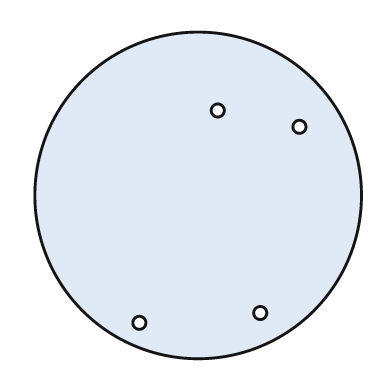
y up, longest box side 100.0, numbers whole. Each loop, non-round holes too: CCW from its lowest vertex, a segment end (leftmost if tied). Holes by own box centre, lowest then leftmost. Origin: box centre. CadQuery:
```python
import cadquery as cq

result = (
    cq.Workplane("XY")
    .moveTo(0.0, 0.0)
    .circle(50.0)
    .moveTo(-18.0, -39.0)
    .circle(2.0)
    .moveTo(19.0, -36.0)
    .circle(2.0)
    .moveTo(31.0, 21.0)
    .circle(2.0)
    .moveTo(6.0, 26.0)
    .circle(2.0)
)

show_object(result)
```